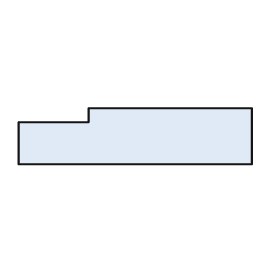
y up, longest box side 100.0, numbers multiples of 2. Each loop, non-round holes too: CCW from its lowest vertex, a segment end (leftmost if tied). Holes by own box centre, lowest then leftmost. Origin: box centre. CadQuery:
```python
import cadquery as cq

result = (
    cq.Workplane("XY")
    .moveTo(-50.0, -12.0)
    .lineTo(50.0, -12.0)
    .lineTo(50.0, 12.0)
    .lineTo(-20.0, 12.0)
    .lineTo(-20.0, 6.0)
    .lineTo(-50.0, 6.0)
    .close()
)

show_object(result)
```